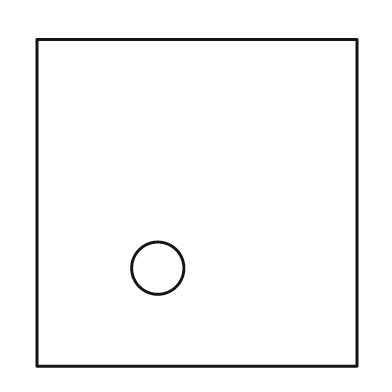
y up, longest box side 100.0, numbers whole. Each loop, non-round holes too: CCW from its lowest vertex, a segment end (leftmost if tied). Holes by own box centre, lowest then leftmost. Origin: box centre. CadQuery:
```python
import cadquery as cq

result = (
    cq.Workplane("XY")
    .moveTo(-49.0, -50.0)
    .lineTo(49.0, -50.0)
    .lineTo(49.0, 50.0)
    .lineTo(-49.0, 50.0)
    .close()
    .moveTo(-12.0, -20.0)
    .circle(8.0)
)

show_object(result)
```